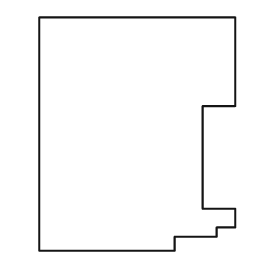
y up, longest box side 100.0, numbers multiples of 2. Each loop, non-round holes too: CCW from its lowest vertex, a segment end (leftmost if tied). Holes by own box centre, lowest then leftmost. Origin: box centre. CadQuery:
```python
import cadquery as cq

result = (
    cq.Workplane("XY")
    .moveTo(-42.0, -50.0)
    .lineTo(16.0, -50.0)
    .lineTo(16.0, -44.0)
    .lineTo(34.0, -44.0)
    .lineTo(34.0, -40.0)
    .lineTo(42.0, -40.0)
    .lineTo(42.0, -32.0)
    .lineTo(28.0, -32.0)
    .lineTo(28.0, 12.0)
    .lineTo(42.0, 12.0)
    .lineTo(42.0, 50.0)
    .lineTo(-42.0, 50.0)
    .close()
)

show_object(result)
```